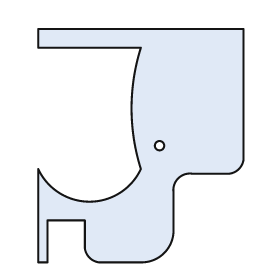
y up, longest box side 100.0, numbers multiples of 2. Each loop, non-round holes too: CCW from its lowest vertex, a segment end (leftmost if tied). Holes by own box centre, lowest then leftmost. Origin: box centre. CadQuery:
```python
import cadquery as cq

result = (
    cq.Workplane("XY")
    .moveTo(-44.0, -50.0)
    .lineTo(-40.0, -50.0)
    .lineTo(-40.0, -32.0)
    .lineTo(-24.0, -32.0)
    .lineTo(-24.0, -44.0)
    .threePointArc((-22.0, -48.0), (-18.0, -50.0))
    .lineTo(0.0, -50.0)
    .threePointArc((10.0, -46.0), (14.0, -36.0))
    .lineTo(14.0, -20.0)
    .threePointArc((16.0, -14.0), (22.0, -12.0))
    .lineTo(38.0, -12.0)
    .threePointArc((42.0, -10.0), (44.0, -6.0))
    .lineTo(44.0, 50.0)
    .lineTo(-44.0, 50.0)
    .lineTo(-44.0, 42.0)
    .lineTo(0.0, 42.0)
    .threePointArc((-4.0, 16.0), (0.0, -10.0))
    .threePointArc((-22.0, -24.0), (-44.0, -10.0))
    .close()
    .moveTo(8.0, 0.0)
    .circle(2.0)
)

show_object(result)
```